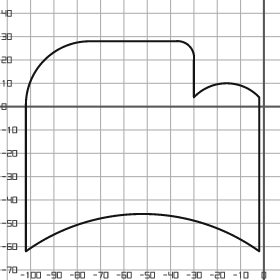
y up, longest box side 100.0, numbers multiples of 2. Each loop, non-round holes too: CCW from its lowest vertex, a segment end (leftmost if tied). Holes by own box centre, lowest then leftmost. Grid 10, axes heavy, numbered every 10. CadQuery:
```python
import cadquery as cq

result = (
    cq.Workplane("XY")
    .moveTo(-102.0, -62.0)
    .threePointArc((-52.0, -46.0), (-2.0, -62.0))
    .lineTo(-2.0, 4.0)
    .threePointArc((-16.0, 10.0), (-30.0, 4.0))
    .lineTo(-30.0, 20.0)
    .threePointArc((-32.0, 26.0), (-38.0, 28.0))
    .lineTo(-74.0, 28.0)
    .threePointArc((-94.0, 20.0), (-102.0, 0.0))
    .close()
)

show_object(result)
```